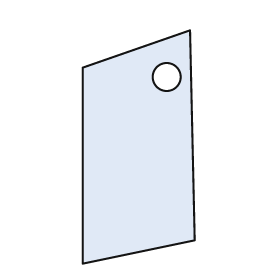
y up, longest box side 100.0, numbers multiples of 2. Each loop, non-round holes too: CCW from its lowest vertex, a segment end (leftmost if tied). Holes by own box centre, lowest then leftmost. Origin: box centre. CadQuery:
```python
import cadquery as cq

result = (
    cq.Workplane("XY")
    .moveTo(-24.0, -50.0)
    .lineTo(24.0, -40.0)
    .lineTo(22.0, 50.0)
    .lineTo(-24.0, 34.0)
    .close()
    .moveTo(12.0, 30.0)
    .circle(6.0)
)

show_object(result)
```